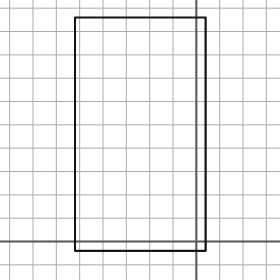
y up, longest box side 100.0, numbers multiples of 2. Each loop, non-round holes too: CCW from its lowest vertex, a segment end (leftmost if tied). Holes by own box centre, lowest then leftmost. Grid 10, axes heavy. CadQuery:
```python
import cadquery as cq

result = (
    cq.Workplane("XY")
    .moveTo(-52.0, -4.0)
    .lineTo(4.0, -4.0)
    .lineTo(4.0, 96.0)
    .lineTo(-52.0, 96.0)
    .close()
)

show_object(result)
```